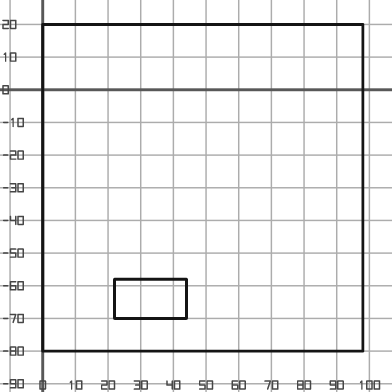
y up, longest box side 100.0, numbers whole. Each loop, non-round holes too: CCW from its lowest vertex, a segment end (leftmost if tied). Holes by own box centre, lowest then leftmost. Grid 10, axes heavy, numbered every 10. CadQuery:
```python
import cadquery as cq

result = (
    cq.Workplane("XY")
    .moveTo(0.0, -80.0)
    .lineTo(98.0, -80.0)
    .lineTo(98.0, 20.0)
    .lineTo(0.0, 20.0)
    .close()
    .moveTo(22.0, -70.0)
    .lineTo(44.0, -70.0)
    .lineTo(44.0, -58.0)
    .lineTo(22.0, -58.0)
    .close()
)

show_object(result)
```